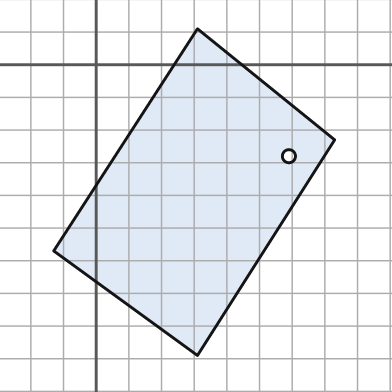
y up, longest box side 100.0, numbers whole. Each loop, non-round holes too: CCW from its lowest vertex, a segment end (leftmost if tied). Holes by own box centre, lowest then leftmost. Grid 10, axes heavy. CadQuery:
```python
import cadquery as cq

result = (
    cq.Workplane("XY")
    .moveTo(31.0, -89.0)
    .lineTo(73.0, -23.0)
    .lineTo(31.0, 11.0)
    .lineTo(-13.0, -57.0)
    .close()
    .moveTo(59.0, -28.0)
    .circle(2.0)
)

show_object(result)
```